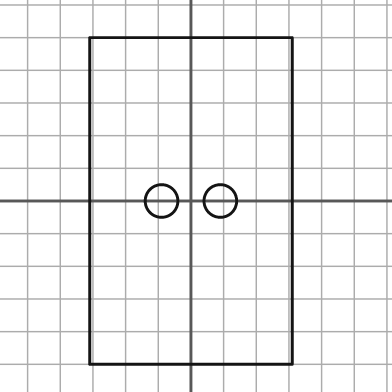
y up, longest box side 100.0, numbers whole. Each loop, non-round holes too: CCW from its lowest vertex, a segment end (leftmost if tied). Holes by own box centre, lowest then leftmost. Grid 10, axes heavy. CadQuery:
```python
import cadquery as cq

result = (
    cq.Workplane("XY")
    .moveTo(-31.0, -50.0)
    .lineTo(31.0, -50.0)
    .lineTo(31.0, 50.0)
    .lineTo(-31.0, 50.0)
    .close()
    .moveTo(-9.0, 0.0)
    .circle(5.0)
    .moveTo(9.0, 0.0)
    .circle(5.0)
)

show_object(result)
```